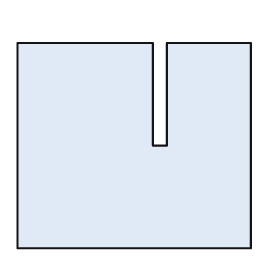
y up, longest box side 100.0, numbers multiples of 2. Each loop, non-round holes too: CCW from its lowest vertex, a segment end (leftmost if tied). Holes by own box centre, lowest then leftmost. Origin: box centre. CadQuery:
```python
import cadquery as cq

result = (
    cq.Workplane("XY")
    .moveTo(-50.0, -44.0)
    .lineTo(50.0, -44.0)
    .lineTo(50.0, 44.0)
    .lineTo(14.0, 44.0)
    .lineTo(14.0, 0.0)
    .lineTo(8.0, 0.0)
    .lineTo(8.0, 44.0)
    .lineTo(-50.0, 44.0)
    .close()
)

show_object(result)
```